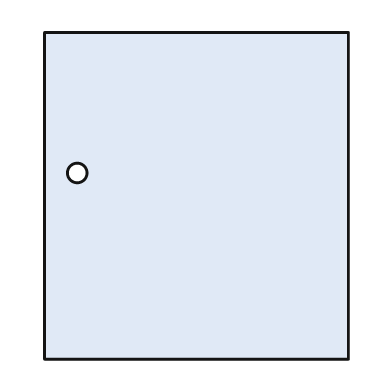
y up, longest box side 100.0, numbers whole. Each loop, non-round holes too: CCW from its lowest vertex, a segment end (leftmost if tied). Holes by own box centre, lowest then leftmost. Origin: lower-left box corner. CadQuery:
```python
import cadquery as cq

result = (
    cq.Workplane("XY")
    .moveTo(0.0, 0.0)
    .lineTo(93.0, 0.0)
    .lineTo(93.0, 100.0)
    .lineTo(0.0, 100.0)
    .close()
    .moveTo(10.0, 57.0)
    .circle(3.0)
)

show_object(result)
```